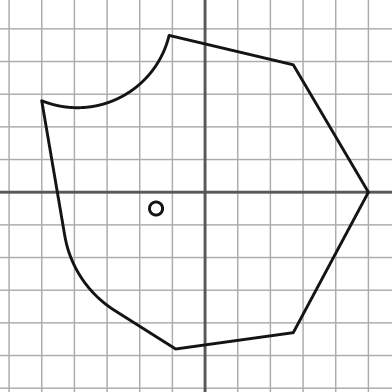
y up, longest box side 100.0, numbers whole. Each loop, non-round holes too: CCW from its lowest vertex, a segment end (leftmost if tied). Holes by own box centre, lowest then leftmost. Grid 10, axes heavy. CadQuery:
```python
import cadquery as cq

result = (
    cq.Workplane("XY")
    .moveTo(-9.0, -48.0)
    .lineTo(27.0, -43.0)
    .lineTo(50.0, 0.0)
    .lineTo(27.0, 39.0)
    .lineTo(-11.0, 48.0)
    .threePointArc((-26.0, 29.0), (-50.0, 28.0))
    .lineTo(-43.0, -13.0)
    .threePointArc((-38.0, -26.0), (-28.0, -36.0))
    .close()
    .moveTo(-15.0, -5.0)
    .circle(2.0)
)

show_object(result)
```